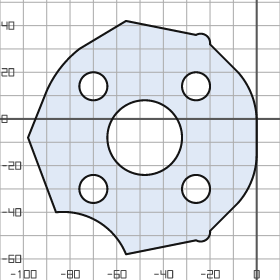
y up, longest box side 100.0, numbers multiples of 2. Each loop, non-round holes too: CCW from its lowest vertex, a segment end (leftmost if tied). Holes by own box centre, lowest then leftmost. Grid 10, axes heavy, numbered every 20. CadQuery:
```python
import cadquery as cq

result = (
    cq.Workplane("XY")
    .moveTo(-56.0, -58.0)
    .lineTo(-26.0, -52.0)
    .threePointArc((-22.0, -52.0), (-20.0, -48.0))
    .lineTo(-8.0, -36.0)
    .threePointArc((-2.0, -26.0), (0.0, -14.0))
    .lineTo(0.0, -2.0)
    .threePointArc((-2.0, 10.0), (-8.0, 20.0))
    .lineTo(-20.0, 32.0)
    .threePointArc((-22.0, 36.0), (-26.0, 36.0))
    .lineTo(-56.0, 42.0)
    .lineTo(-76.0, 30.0)
    .threePointArc((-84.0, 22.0), (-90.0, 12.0))
    .lineTo(-98.0, -8.0)
    .lineTo(-86.0, -40.0)
    .threePointArc((-68.0, -44.0), (-56.0, -58.0))
    .close()
    .moveTo(-70.0, -30.0)
    .circle(6.0)
    .moveTo(-26.0, -30.0)
    .circle(6.0)
    .moveTo(-48.0, -8.0)
    .circle(16.0)
    .moveTo(-70.0, 14.0)
    .circle(6.0)
    .moveTo(-26.0, 14.0)
    .circle(6.0)
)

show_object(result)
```